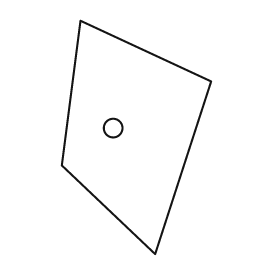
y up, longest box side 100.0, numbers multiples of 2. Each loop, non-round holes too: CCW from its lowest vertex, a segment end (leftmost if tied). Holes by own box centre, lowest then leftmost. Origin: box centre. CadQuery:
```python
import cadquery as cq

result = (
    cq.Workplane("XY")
    .moveTo(8.0, -50.0)
    .lineTo(32.0, 24.0)
    .lineTo(-24.0, 50.0)
    .lineTo(-32.0, -12.0)
    .close()
    .moveTo(-10.0, 4.0)
    .circle(4.0)
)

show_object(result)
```